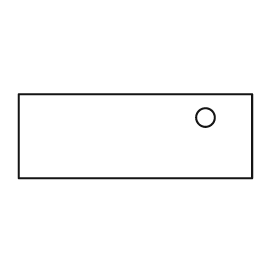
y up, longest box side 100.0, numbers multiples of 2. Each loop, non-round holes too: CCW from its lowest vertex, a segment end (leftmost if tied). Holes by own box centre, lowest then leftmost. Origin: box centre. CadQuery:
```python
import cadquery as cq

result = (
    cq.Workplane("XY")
    .moveTo(-50.0, -18.0)
    .lineTo(50.0, -18.0)
    .lineTo(50.0, 18.0)
    .lineTo(-50.0, 18.0)
    .close()
    .moveTo(30.0, 8.0)
    .circle(4.0)
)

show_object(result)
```